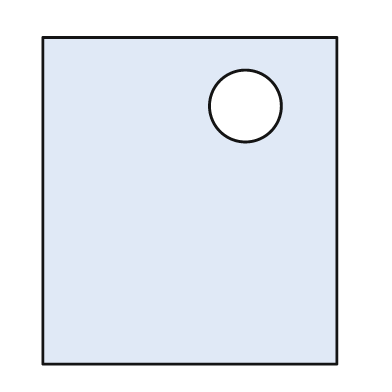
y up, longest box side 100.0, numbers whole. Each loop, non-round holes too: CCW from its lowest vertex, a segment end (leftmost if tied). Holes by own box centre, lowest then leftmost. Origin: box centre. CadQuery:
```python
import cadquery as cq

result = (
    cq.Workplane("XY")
    .moveTo(-45.0, -50.0)
    .lineTo(45.0, -50.0)
    .lineTo(45.0, 50.0)
    .lineTo(-45.0, 50.0)
    .close()
    .moveTo(17.0, 29.0)
    .circle(11.0)
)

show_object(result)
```